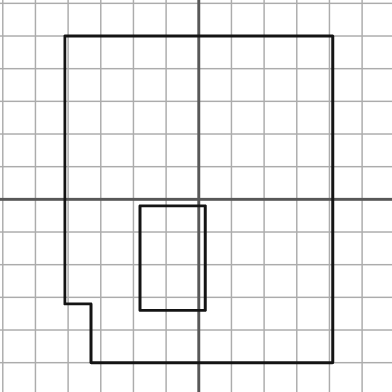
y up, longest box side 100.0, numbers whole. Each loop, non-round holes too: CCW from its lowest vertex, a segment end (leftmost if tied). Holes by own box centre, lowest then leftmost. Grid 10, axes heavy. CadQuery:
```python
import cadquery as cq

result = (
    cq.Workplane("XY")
    .moveTo(-33.0, -50.0)
    .lineTo(41.0, -50.0)
    .lineTo(41.0, 50.0)
    .lineTo(-41.0, 50.0)
    .lineTo(-41.0, -32.0)
    .lineTo(-33.0, -32.0)
    .close()
    .moveTo(-18.0, -34.0)
    .lineTo(2.0, -34.0)
    .lineTo(2.0, -2.0)
    .lineTo(-18.0, -2.0)
    .close()
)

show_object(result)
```